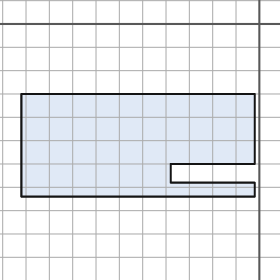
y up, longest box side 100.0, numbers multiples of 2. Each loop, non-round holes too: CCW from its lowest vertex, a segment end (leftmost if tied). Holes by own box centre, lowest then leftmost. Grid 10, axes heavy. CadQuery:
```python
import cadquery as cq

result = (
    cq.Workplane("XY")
    .moveTo(-102.0, -74.0)
    .lineTo(-2.0, -74.0)
    .lineTo(-2.0, -68.0)
    .lineTo(-38.0, -68.0)
    .lineTo(-38.0, -60.0)
    .lineTo(-2.0, -60.0)
    .lineTo(-2.0, -30.0)
    .lineTo(-102.0, -30.0)
    .close()
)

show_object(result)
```